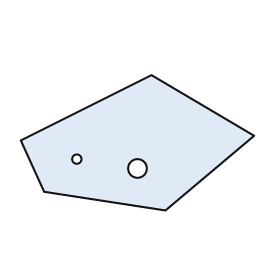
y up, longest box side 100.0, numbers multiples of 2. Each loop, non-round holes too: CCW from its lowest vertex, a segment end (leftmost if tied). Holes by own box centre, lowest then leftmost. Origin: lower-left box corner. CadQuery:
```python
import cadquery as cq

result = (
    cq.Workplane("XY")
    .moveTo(62.0, 0.0)
    .lineTo(100.0, 32.0)
    .lineTo(56.0, 58.0)
    .lineTo(0.0, 30.0)
    .lineTo(10.0, 8.0)
    .close()
    .moveTo(50.0, 18.0)
    .circle(4.0)
    .moveTo(24.0, 22.0)
    .circle(2.0)
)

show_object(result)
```